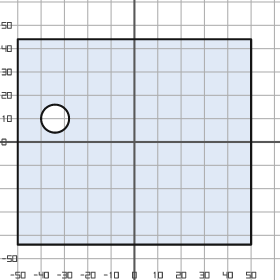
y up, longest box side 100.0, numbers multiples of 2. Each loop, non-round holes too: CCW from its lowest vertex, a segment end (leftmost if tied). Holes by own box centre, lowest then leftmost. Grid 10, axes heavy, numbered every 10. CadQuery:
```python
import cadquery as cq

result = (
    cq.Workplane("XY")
    .moveTo(-50.0, -44.0)
    .lineTo(50.0, -44.0)
    .lineTo(50.0, 44.0)
    .lineTo(-50.0, 44.0)
    .close()
    .moveTo(-34.0, 10.0)
    .circle(6.0)
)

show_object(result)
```